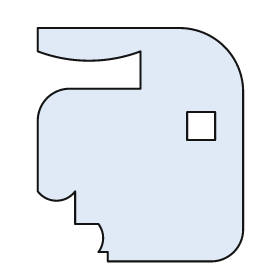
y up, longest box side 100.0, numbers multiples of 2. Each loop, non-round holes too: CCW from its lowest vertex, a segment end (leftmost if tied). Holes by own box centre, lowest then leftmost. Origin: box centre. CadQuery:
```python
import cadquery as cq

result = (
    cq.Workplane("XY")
    .moveTo(-14.0, -50.0)
    .lineTo(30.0, -50.0)
    .threePointArc((40.0, -46.0), (44.0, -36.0))
    .lineTo(44.0, 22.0)
    .threePointArc((36.0, 42.0), (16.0, 50.0))
    .lineTo(-44.0, 50.0)
    .lineTo(-44.0, 40.0)
    .threePointArc((-22.0, 36.0), (0.0, 40.0))
    .lineTo(0.0, 24.0)
    .lineTo(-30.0, 24.0)
    .threePointArc((-40.0, 20.0), (-44.0, 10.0))
    .lineTo(-44.0, -20.0)
    .threePointArc((-36.0, -24.0), (-28.0, -20.0))
    .lineTo(-28.0, -34.0)
    .lineTo(-18.0, -34.0)
    .threePointArc((-16.0, -40.0), (-18.0, -46.0))
    .lineTo(-14.0, -46.0)
    .close()
    .moveTo(20.0, 2.0)
    .lineTo(32.0, 2.0)
    .lineTo(32.0, 14.0)
    .lineTo(20.0, 14.0)
    .close()
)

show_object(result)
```